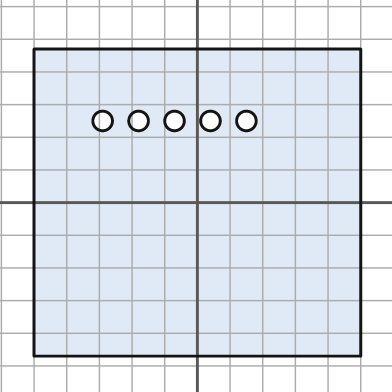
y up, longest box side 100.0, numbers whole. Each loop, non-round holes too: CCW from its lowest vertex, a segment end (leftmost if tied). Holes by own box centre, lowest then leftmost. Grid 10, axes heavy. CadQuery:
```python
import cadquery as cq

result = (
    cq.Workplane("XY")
    .moveTo(-50.0, -47.0)
    .lineTo(50.0, -47.0)
    .lineTo(50.0, 47.0)
    .lineTo(-50.0, 47.0)
    .close()
    .moveTo(-29.0, 25.0)
    .circle(3.0)
    .moveTo(-18.0, 25.0)
    .circle(3.0)
    .moveTo(-7.0, 25.0)
    .circle(3.0)
    .moveTo(4.0, 25.0)
    .circle(3.0)
    .moveTo(15.0, 25.0)
    .circle(3.0)
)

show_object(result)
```